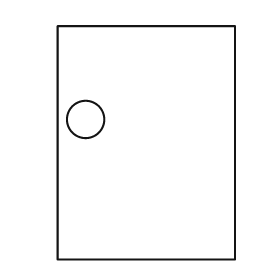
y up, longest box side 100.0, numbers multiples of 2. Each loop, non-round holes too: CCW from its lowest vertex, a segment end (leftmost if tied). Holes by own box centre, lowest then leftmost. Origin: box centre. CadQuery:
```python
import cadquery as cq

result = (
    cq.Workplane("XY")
    .moveTo(-38.0, -50.0)
    .lineTo(38.0, -50.0)
    .lineTo(38.0, 50.0)
    .lineTo(-38.0, 50.0)
    .close()
    .moveTo(-26.0, 10.0)
    .circle(8.0)
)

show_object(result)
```